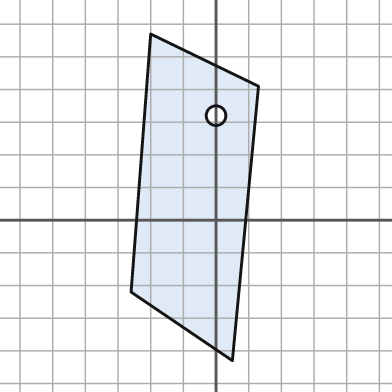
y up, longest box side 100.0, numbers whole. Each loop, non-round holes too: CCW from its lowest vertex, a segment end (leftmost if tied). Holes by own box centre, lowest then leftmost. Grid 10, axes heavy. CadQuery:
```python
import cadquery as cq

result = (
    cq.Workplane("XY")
    .moveTo(5.0, -43.0)
    .lineTo(13.0, 41.0)
    .lineTo(-20.0, 57.0)
    .lineTo(-26.0, -22.0)
    .close()
    .moveTo(0.0, 32.0)
    .circle(3.0)
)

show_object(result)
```